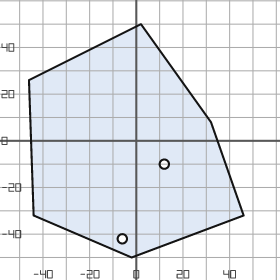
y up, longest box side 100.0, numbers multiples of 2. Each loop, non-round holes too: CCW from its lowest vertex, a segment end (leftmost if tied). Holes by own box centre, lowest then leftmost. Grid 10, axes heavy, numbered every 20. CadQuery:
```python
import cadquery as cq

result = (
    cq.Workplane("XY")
    .moveTo(-2.0, -50.0)
    .lineTo(46.0, -32.0)
    .lineTo(32.0, 8.0)
    .lineTo(2.0, 50.0)
    .lineTo(-46.0, 26.0)
    .lineTo(-44.0, -32.0)
    .close()
    .moveTo(-6.0, -42.0)
    .circle(2.0)
    .moveTo(12.0, -10.0)
    .circle(2.0)
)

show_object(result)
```